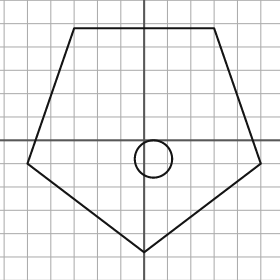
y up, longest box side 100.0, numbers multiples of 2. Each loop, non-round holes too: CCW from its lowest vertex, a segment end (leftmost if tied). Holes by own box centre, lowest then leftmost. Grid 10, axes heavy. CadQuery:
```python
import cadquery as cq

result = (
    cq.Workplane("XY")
    .moveTo(0.0, -48.0)
    .lineTo(50.0, -10.0)
    .lineTo(30.0, 48.0)
    .lineTo(-30.0, 48.0)
    .lineTo(-50.0, -10.0)
    .close()
    .moveTo(4.0, -8.0)
    .circle(8.0)
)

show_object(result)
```